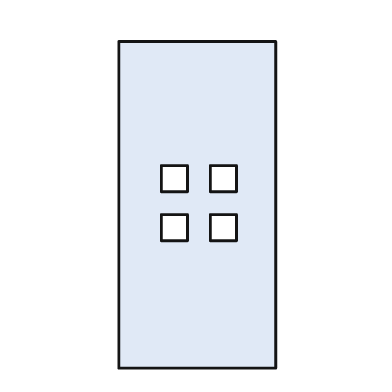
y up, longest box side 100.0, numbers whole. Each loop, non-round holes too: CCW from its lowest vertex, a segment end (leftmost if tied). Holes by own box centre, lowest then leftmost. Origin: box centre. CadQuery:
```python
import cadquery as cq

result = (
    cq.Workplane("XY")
    .moveTo(-24.0, -50.0)
    .lineTo(24.0, -50.0)
    .lineTo(24.0, 50.0)
    .lineTo(-24.0, 50.0)
    .close()
    .moveTo(-11.0, -11.0)
    .lineTo(-3.0, -11.0)
    .lineTo(-3.0, -3.0)
    .lineTo(-11.0, -3.0)
    .close()
    .moveTo(4.0, -11.0)
    .lineTo(12.0, -11.0)
    .lineTo(12.0, -3.0)
    .lineTo(4.0, -3.0)
    .close()
    .moveTo(-11.0, 4.0)
    .lineTo(-3.0, 4.0)
    .lineTo(-3.0, 12.0)
    .lineTo(-11.0, 12.0)
    .close()
    .moveTo(4.0, 4.0)
    .lineTo(12.0, 4.0)
    .lineTo(12.0, 12.0)
    .lineTo(4.0, 12.0)
    .close()
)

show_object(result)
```